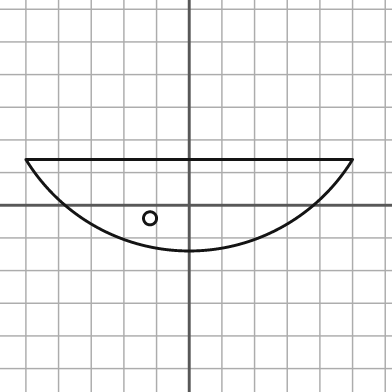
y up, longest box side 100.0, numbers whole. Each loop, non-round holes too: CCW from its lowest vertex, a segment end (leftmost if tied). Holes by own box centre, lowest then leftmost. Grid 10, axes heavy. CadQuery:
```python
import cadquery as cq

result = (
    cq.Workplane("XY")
    .moveTo(-50.0, 14.0)
    .threePointArc((0.0, -14.0), (50.0, 14.0))
    .close()
    .moveTo(-12.0, -4.0)
    .circle(2.0)
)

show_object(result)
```